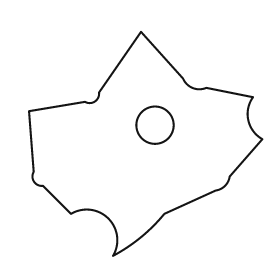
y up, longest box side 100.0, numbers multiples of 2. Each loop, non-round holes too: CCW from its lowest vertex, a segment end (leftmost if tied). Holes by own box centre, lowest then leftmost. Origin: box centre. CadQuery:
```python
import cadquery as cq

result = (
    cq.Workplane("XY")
    .moveTo(-14.0, -48.0)
    .threePointArc((-2.0, -40.0), (8.0, -30.0))
    .lineTo(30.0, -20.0)
    .threePointArc((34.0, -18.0), (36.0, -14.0))
    .lineTo(50.0, 2.0)
    .threePointArc((44.0, 10.0), (46.0, 20.0))
    .lineTo(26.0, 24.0)
    .threePointArc((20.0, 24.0), (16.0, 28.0))
    .lineTo(-2.0, 48.0)
    .lineTo(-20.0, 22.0)
    .threePointArc((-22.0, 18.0), (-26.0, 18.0))
    .lineTo(-50.0, 14.0)
    .lineTo(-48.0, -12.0)
    .threePointArc((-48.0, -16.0), (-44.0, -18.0))
    .lineTo(-32.0, -30.0)
    .threePointArc((-16.0, -32.0), (-14.0, -48.0))
    .close()
    .moveTo(4.0, 8.0)
    .circle(8.0)
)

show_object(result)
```